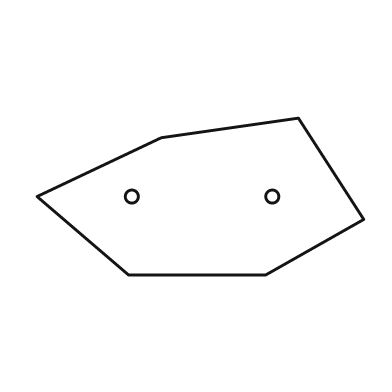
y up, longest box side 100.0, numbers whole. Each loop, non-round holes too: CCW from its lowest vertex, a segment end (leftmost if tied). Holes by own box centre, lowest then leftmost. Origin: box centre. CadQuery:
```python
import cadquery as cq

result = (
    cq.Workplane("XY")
    .moveTo(-22.0, -24.0)
    .lineTo(20.0, -24.0)
    .lineTo(50.0, -7.0)
    .lineTo(30.0, 24.0)
    .lineTo(-12.0, 18.0)
    .lineTo(-50.0, 0.0)
    .close()
    .moveTo(-21.0, 0.0)
    .circle(2.0)
    .moveTo(22.0, 0.0)
    .circle(2.0)
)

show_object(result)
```